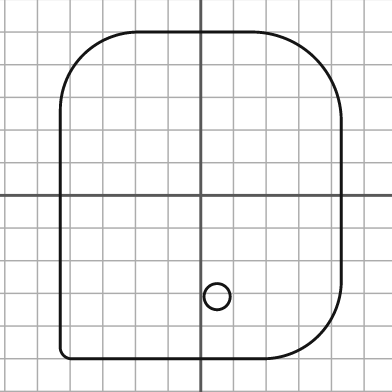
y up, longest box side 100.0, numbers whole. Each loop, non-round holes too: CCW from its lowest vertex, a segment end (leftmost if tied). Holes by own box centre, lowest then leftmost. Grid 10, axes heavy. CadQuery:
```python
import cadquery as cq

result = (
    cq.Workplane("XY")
    .moveTo(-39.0, -50.0)
    .lineTo(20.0, -50.0)
    .threePointArc((36.0, -43.0), (43.0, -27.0))
    .lineTo(43.0, 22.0)
    .threePointArc((35.0, 42.0), (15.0, 50.0))
    .lineTo(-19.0, 50.0)
    .threePointArc((-36.0, 43.0), (-43.0, 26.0))
    .lineTo(-43.0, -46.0)
    .threePointArc((-42.0, -49.0), (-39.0, -50.0))
    .close()
    .moveTo(5.0, -31.0)
    .circle(4.0)
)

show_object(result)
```